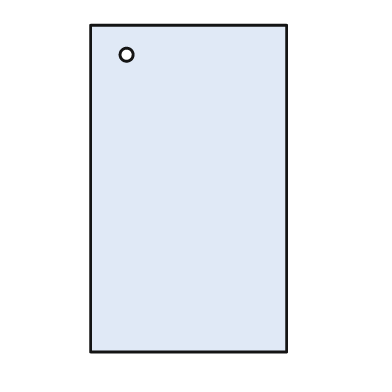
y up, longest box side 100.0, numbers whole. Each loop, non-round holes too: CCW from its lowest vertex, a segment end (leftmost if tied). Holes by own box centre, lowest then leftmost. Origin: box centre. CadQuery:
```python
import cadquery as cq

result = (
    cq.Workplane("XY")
    .moveTo(-30.0, -50.0)
    .lineTo(30.0, -50.0)
    .lineTo(30.0, 50.0)
    .lineTo(-30.0, 50.0)
    .close()
    .moveTo(-19.0, 41.0)
    .circle(2.0)
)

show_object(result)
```